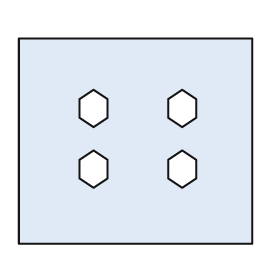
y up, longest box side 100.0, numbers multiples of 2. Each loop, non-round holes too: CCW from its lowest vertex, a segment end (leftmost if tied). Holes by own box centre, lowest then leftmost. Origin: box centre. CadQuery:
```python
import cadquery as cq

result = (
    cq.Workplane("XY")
    .moveTo(-50.0, -44.0)
    .lineTo(50.0, -44.0)
    .lineTo(50.0, 44.0)
    .lineTo(-50.0, 44.0)
    .close()
    .moveTo(-18.0, -20.0)
    .lineTo(-12.0, -16.0)
    .lineTo(-12.0, -8.0)
    .lineTo(-18.0, -4.0)
    .lineTo(-24.0, -8.0)
    .lineTo(-24.0, -16.0)
    .close()
    .moveTo(20.0, -20.0)
    .lineTo(26.0, -16.0)
    .lineTo(26.0, -8.0)
    .lineTo(20.0, -4.0)
    .lineTo(14.0, -8.0)
    .lineTo(14.0, -16.0)
    .close()
    .moveTo(-18.0, 6.0)
    .lineTo(-12.0, 10.0)
    .lineTo(-12.0, 18.0)
    .lineTo(-18.0, 22.0)
    .lineTo(-24.0, 18.0)
    .lineTo(-24.0, 10.0)
    .close()
    .moveTo(20.0, 6.0)
    .lineTo(26.0, 10.0)
    .lineTo(26.0, 18.0)
    .lineTo(20.0, 22.0)
    .lineTo(14.0, 18.0)
    .lineTo(14.0, 10.0)
    .close()
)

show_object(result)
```